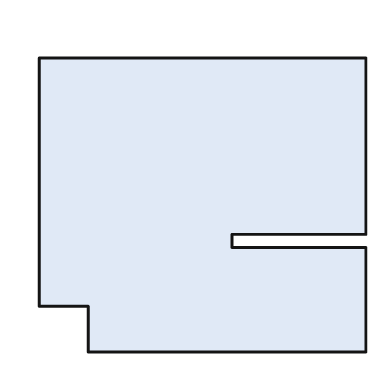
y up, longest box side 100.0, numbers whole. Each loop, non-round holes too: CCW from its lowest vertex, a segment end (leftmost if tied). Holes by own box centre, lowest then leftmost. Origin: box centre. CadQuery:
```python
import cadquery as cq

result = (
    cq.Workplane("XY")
    .moveTo(-35.0, -45.0)
    .lineTo(50.0, -45.0)
    .lineTo(50.0, -13.0)
    .lineTo(9.0, -13.0)
    .lineTo(9.0, -9.0)
    .lineTo(50.0, -9.0)
    .lineTo(50.0, 45.0)
    .lineTo(-50.0, 45.0)
    .lineTo(-50.0, -31.0)
    .lineTo(-35.0, -31.0)
    .close()
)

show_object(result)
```